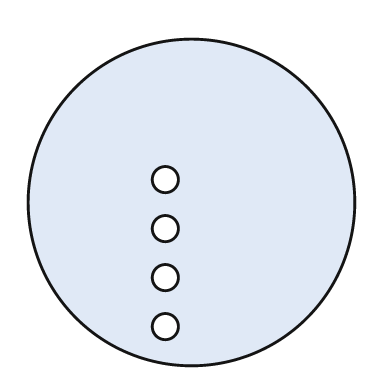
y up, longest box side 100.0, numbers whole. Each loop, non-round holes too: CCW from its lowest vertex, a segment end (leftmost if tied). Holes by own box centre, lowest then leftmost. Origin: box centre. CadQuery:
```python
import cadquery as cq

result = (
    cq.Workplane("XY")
    .moveTo(0.0, 0.0)
    .circle(50.0)
    .moveTo(-8.0, -38.0)
    .circle(4.0)
    .moveTo(-8.0, -23.0)
    .circle(4.0)
    .moveTo(-8.0, -8.0)
    .circle(4.0)
    .moveTo(-8.0, 7.0)
    .circle(4.0)
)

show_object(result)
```